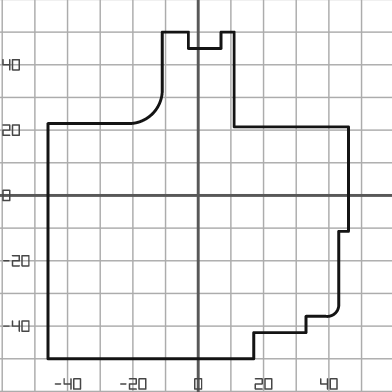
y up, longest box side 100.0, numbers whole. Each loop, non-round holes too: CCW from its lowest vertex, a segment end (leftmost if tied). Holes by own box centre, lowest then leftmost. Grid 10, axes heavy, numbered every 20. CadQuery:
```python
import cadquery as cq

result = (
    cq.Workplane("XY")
    .moveTo(-46.0, -50.0)
    .lineTo(17.0, -50.0)
    .lineTo(17.0, -42.0)
    .lineTo(33.0, -42.0)
    .lineTo(33.0, -37.0)
    .lineTo(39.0, -37.0)
    .threePointArc((42.0, -36.0), (43.0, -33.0))
    .lineTo(43.0, -11.0)
    .lineTo(46.0, -11.0)
    .lineTo(46.0, 21.0)
    .lineTo(11.0, 21.0)
    .lineTo(11.0, 50.0)
    .lineTo(7.0, 50.0)
    .lineTo(7.0, 45.0)
    .lineTo(-3.0, 45.0)
    .lineTo(-3.0, 50.0)
    .lineTo(-11.0, 50.0)
    .lineTo(-11.0, 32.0)
    .threePointArc((-14.0, 25.0), (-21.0, 22.0))
    .lineTo(-46.0, 22.0)
    .close()
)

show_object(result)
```